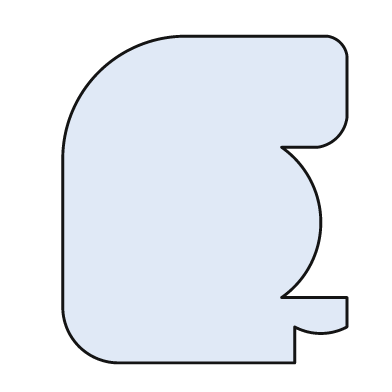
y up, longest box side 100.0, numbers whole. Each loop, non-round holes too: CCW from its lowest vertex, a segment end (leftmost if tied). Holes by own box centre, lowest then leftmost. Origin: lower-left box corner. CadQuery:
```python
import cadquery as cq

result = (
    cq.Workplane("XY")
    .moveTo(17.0, 0.0)
    .lineTo(71.0, 0.0)
    .lineTo(71.0, 11.0)
    .threePointArc((79.0, 9.0), (87.0, 11.0))
    .lineTo(87.0, 20.0)
    .lineTo(67.0, 20.0)
    .threePointArc((79.0, 43.0), (67.0, 66.0))
    .lineTo(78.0, 66.0)
    .threePointArc((84.0, 69.0), (87.0, 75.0))
    .lineTo(87.0, 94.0)
    .threePointArc((85.0, 98.0), (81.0, 100.0))
    .lineTo(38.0, 100.0)
    .threePointArc((11.0, 89.0), (0.0, 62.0))
    .lineTo(0.0, 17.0)
    .threePointArc((5.0, 5.0), (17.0, 0.0))
    .close()
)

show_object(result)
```